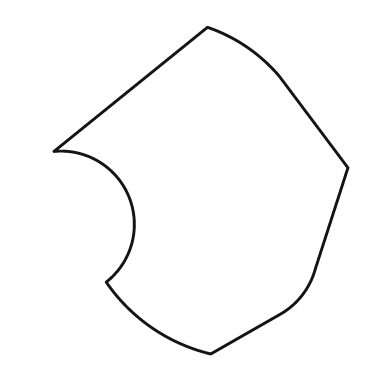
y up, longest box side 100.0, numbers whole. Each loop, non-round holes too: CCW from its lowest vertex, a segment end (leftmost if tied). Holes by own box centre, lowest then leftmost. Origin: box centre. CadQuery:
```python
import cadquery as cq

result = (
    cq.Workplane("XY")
    .moveTo(3.0, -50.0)
    .lineTo(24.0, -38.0)
    .threePointArc((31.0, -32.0), (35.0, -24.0))
    .lineTo(45.0, 7.0)
    .lineTo(24.0, 35.0)
    .threePointArc((14.0, 44.0), (2.0, 50.0))
    .lineTo(-45.0, 12.0)
    .threePointArc((-22.0, -2.0), (-29.0, -28.0))
    .threePointArc((-15.0, -42.0), (3.0, -50.0))
    .close()
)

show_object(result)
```